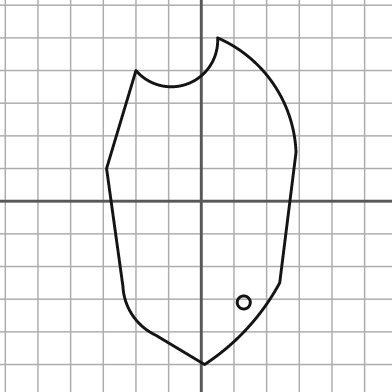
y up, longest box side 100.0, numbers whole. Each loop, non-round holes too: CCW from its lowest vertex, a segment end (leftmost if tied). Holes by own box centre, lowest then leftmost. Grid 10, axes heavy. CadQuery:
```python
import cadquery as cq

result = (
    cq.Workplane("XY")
    .moveTo(1.0, -50.0)
    .threePointArc((14.0, -39.0), (24.0, -25.0))
    .lineTo(29.0, 15.0)
    .threePointArc((22.0, 36.0), (5.0, 50.0))
    .threePointArc((-4.0, 36.0), (-20.0, 40.0))
    .lineTo(-29.0, 10.0)
    .lineTo(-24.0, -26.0)
    .threePointArc((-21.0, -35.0), (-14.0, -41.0))
    .close()
    .moveTo(13.0, -31.0)
    .circle(2.0)
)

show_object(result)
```